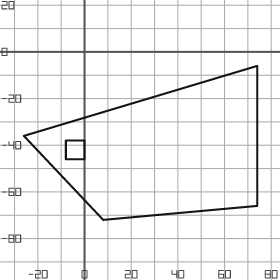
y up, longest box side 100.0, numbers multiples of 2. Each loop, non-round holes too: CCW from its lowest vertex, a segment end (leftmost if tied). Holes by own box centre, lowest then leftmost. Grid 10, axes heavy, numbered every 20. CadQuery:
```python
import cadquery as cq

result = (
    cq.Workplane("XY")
    .moveTo(8.0, -72.0)
    .lineTo(74.0, -66.0)
    .lineTo(74.0, -6.0)
    .lineTo(-26.0, -36.0)
    .close()
    .moveTo(-8.0, -46.0)
    .lineTo(0.0, -46.0)
    .lineTo(0.0, -38.0)
    .lineTo(-8.0, -38.0)
    .close()
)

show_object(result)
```